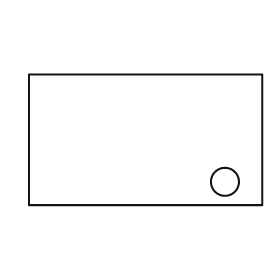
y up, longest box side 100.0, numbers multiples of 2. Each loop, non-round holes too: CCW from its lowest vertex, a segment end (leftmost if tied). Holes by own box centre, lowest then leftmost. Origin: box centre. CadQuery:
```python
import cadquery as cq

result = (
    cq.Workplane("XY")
    .moveTo(-50.0, -28.0)
    .lineTo(50.0, -28.0)
    .lineTo(50.0, 28.0)
    .lineTo(-50.0, 28.0)
    .close()
    .moveTo(34.0, -18.0)
    .circle(6.0)
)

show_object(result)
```